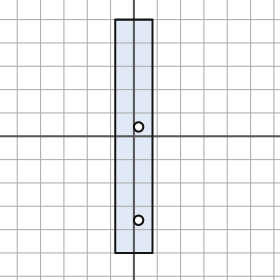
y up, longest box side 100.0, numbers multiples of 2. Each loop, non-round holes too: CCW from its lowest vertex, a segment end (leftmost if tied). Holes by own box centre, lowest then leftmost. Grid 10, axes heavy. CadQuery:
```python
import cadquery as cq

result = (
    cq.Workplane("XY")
    .moveTo(-8.0, -50.0)
    .lineTo(8.0, -50.0)
    .lineTo(8.0, 50.0)
    .lineTo(-8.0, 50.0)
    .close()
    .moveTo(2.0, -36.0)
    .circle(2.0)
    .moveTo(2.0, 4.0)
    .circle(2.0)
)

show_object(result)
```